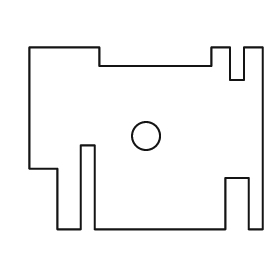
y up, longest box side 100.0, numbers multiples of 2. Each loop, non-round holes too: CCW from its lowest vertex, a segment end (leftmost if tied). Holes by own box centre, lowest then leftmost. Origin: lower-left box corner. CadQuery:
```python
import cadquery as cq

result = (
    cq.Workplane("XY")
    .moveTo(12.0, 0.0)
    .lineTo(22.0, 0.0)
    .lineTo(22.0, 36.0)
    .lineTo(28.0, 36.0)
    .lineTo(28.0, 0.0)
    .lineTo(84.0, 0.0)
    .lineTo(84.0, 22.0)
    .lineTo(94.0, 22.0)
    .lineTo(94.0, 0.0)
    .lineTo(100.0, 0.0)
    .lineTo(100.0, 78.0)
    .lineTo(92.0, 78.0)
    .lineTo(92.0, 64.0)
    .lineTo(86.0, 64.0)
    .lineTo(86.0, 78.0)
    .lineTo(78.0, 78.0)
    .lineTo(78.0, 70.0)
    .lineTo(30.0, 70.0)
    .lineTo(30.0, 78.0)
    .lineTo(0.0, 78.0)
    .lineTo(0.0, 26.0)
    .lineTo(12.0, 26.0)
    .close()
    .moveTo(50.0, 40.0)
    .circle(6.0)
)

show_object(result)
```